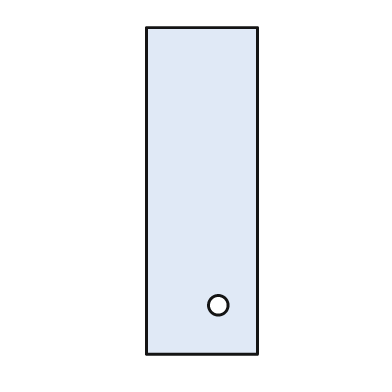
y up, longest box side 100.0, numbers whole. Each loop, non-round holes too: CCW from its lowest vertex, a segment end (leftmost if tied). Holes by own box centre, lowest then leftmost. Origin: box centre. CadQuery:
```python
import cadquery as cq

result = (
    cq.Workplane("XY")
    .moveTo(-17.0, -50.0)
    .lineTo(17.0, -50.0)
    .lineTo(17.0, 50.0)
    .lineTo(-17.0, 50.0)
    .close()
    .moveTo(5.0, -35.0)
    .circle(3.0)
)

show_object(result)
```